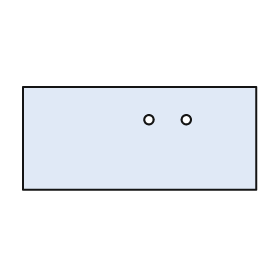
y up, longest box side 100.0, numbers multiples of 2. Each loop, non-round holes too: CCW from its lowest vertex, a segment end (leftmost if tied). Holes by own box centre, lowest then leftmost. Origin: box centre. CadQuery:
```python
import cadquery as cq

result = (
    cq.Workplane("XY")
    .moveTo(-50.0, -22.0)
    .lineTo(50.0, -22.0)
    .lineTo(50.0, 22.0)
    .lineTo(-50.0, 22.0)
    .close()
    .moveTo(4.0, 8.0)
    .circle(2.0)
    .moveTo(20.0, 8.0)
    .circle(2.0)
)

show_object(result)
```